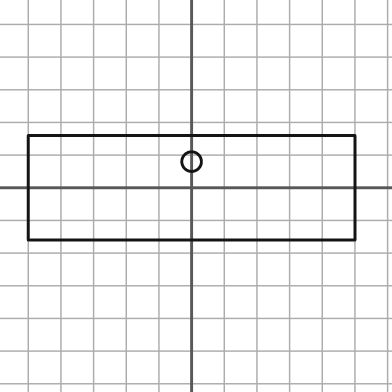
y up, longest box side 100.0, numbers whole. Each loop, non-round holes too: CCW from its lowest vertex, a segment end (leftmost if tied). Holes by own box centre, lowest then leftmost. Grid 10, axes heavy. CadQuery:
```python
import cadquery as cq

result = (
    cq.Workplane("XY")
    .moveTo(-50.0, -16.0)
    .lineTo(50.0, -16.0)
    .lineTo(50.0, 16.0)
    .lineTo(-50.0, 16.0)
    .close()
    .moveTo(0.0, 8.0)
    .circle(3.0)
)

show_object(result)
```